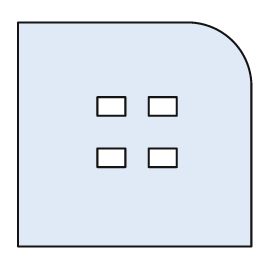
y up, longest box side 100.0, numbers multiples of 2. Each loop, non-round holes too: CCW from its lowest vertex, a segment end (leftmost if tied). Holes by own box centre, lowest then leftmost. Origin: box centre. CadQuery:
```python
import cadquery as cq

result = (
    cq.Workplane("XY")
    .moveTo(-50.0, -48.0)
    .lineTo(50.0, -48.0)
    .lineTo(50.0, 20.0)
    .threePointArc((42.0, 40.0), (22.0, 48.0))
    .lineTo(-50.0, 48.0)
    .close()
    .moveTo(-16.0, -14.0)
    .lineTo(-4.0, -14.0)
    .lineTo(-4.0, -6.0)
    .lineTo(-16.0, -6.0)
    .close()
    .moveTo(6.0, -14.0)
    .lineTo(18.0, -14.0)
    .lineTo(18.0, -6.0)
    .lineTo(6.0, -6.0)
    .close()
    .moveTo(-16.0, 8.0)
    .lineTo(-4.0, 8.0)
    .lineTo(-4.0, 16.0)
    .lineTo(-16.0, 16.0)
    .close()
    .moveTo(6.0, 8.0)
    .lineTo(18.0, 8.0)
    .lineTo(18.0, 16.0)
    .lineTo(6.0, 16.0)
    .close()
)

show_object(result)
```